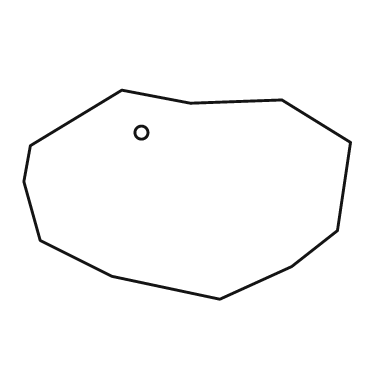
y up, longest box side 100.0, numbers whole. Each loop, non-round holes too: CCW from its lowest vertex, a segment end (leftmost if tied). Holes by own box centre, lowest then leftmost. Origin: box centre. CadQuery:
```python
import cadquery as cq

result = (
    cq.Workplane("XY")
    .moveTo(10.0, -32.0)
    .lineTo(32.0, -22.0)
    .lineTo(46.0, -11.0)
    .lineTo(50.0, 16.0)
    .lineTo(29.0, 29.0)
    .lineTo(1.0, 28.0)
    .lineTo(-20.0, 32.0)
    .lineTo(-48.0, 15.0)
    .lineTo(-50.0, 4.0)
    .lineTo(-45.0, -14.0)
    .lineTo(-23.0, -25.0)
    .close()
    .moveTo(-14.0, 19.0)
    .circle(2.0)
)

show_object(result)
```